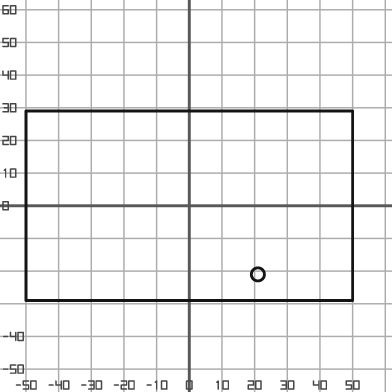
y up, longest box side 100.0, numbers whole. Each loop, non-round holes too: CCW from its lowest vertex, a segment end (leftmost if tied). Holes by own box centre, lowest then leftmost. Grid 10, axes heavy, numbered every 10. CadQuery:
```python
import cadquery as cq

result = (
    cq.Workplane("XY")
    .moveTo(-50.0, -29.0)
    .lineTo(50.0, -29.0)
    .lineTo(50.0, 29.0)
    .lineTo(-50.0, 29.0)
    .close()
    .moveTo(21.0, -21.0)
    .circle(2.0)
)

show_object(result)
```